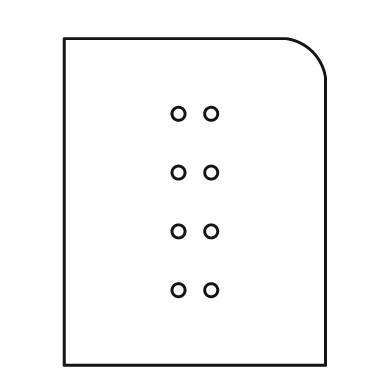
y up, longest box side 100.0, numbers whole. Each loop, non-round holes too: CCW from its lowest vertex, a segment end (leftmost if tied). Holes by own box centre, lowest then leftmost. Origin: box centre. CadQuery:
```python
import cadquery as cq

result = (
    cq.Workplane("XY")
    .moveTo(-40.0, -50.0)
    .lineTo(40.0, -50.0)
    .lineTo(40.0, 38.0)
    .threePointArc((36.0, 46.0), (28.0, 50.0))
    .lineTo(-40.0, 50.0)
    .close()
    .moveTo(-5.0, -27.0)
    .circle(2.0)
    .moveTo(5.0, -27.0)
    .circle(2.0)
    .moveTo(-5.0, -9.0)
    .circle(2.0)
    .moveTo(5.0, -9.0)
    .circle(2.0)
    .moveTo(-5.0, 9.0)
    .circle(2.0)
    .moveTo(5.0, 9.0)
    .circle(2.0)
    .moveTo(-5.0, 27.0)
    .circle(2.0)
    .moveTo(5.0, 27.0)
    .circle(2.0)
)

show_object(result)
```